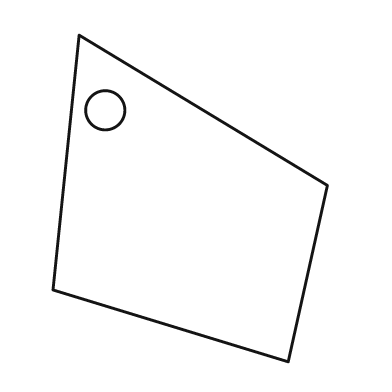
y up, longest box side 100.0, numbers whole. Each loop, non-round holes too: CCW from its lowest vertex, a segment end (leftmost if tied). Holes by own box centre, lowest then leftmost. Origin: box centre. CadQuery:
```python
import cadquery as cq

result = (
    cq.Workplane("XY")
    .moveTo(30.0, -50.0)
    .lineTo(42.0, 4.0)
    .lineTo(-34.0, 50.0)
    .lineTo(-42.0, -28.0)
    .close()
    .moveTo(-26.0, 27.0)
    .circle(6.0)
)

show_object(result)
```